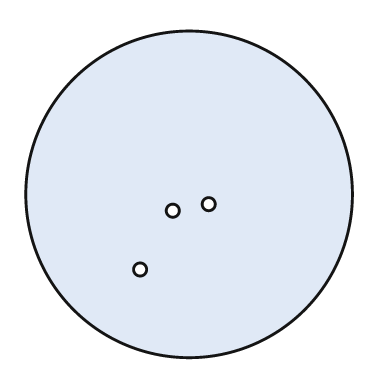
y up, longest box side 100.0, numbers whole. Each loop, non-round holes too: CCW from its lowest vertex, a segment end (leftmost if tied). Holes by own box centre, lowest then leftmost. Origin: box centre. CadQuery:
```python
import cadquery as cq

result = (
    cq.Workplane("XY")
    .moveTo(0.0, 0.0)
    .circle(50.0)
    .moveTo(-15.0, -23.0)
    .circle(2.0)
    .moveTo(-5.0, -5.0)
    .circle(2.0)
    .moveTo(6.0, -3.0)
    .circle(2.0)
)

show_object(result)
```